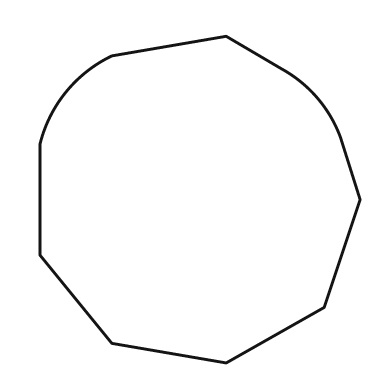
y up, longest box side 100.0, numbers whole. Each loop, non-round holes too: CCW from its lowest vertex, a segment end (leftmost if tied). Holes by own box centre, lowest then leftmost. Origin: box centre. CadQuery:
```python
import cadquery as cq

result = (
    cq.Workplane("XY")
    .moveTo(8.0, -50.0)
    .lineTo(38.0, -33.0)
    .lineTo(49.0, 0.0)
    .lineTo(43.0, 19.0)
    .threePointArc((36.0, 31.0), (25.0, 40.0))
    .lineTo(8.0, 50.0)
    .lineTo(-27.0, 44.0)
    .threePointArc((-41.0, 33.0), (-49.0, 17.0))
    .lineTo(-49.0, -17.0)
    .lineTo(-27.0, -44.0)
    .close()
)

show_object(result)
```